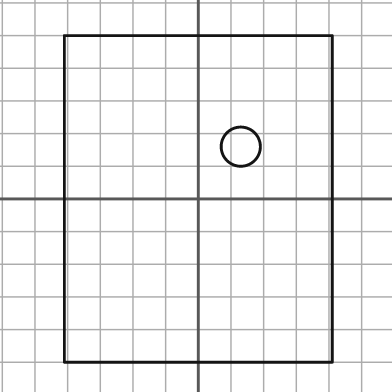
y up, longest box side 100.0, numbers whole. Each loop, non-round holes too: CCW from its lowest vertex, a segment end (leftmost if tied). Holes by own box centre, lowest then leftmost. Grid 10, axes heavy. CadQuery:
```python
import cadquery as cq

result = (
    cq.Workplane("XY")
    .moveTo(-41.0, -50.0)
    .lineTo(41.0, -50.0)
    .lineTo(41.0, 50.0)
    .lineTo(-41.0, 50.0)
    .close()
    .moveTo(13.0, 16.0)
    .circle(6.0)
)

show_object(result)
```